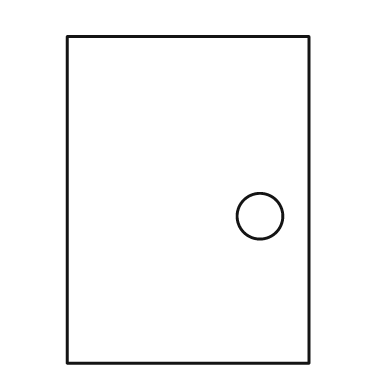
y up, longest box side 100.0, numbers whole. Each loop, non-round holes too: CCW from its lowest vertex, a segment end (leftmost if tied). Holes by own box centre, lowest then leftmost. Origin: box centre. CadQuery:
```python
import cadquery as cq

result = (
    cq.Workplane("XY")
    .moveTo(-37.0, -50.0)
    .lineTo(37.0, -50.0)
    .lineTo(37.0, 50.0)
    .lineTo(-37.0, 50.0)
    .close()
    .moveTo(22.0, -5.0)
    .circle(7.0)
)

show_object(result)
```